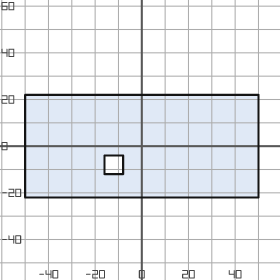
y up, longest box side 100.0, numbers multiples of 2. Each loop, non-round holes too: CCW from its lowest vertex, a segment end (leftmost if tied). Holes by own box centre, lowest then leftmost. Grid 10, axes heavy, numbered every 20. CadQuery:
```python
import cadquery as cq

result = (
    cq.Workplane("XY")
    .moveTo(-50.0, -22.0)
    .lineTo(50.0, -22.0)
    .lineTo(50.0, 22.0)
    .lineTo(-50.0, 22.0)
    .close()
    .moveTo(-16.0, -12.0)
    .lineTo(-8.0, -12.0)
    .lineTo(-8.0, -4.0)
    .lineTo(-16.0, -4.0)
    .close()
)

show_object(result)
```